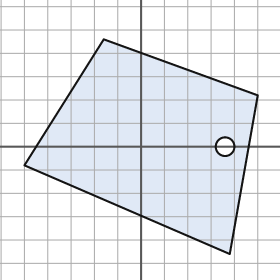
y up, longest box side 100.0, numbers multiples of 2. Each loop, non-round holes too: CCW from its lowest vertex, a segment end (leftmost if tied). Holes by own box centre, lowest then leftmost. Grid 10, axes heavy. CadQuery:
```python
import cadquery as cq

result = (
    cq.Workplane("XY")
    .moveTo(38.0, -46.0)
    .lineTo(50.0, 22.0)
    .lineTo(-16.0, 46.0)
    .lineTo(-50.0, -8.0)
    .close()
    .moveTo(36.0, 0.0)
    .circle(4.0)
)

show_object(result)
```